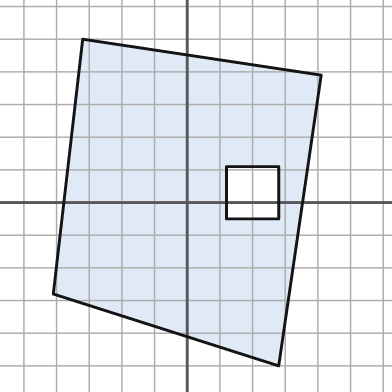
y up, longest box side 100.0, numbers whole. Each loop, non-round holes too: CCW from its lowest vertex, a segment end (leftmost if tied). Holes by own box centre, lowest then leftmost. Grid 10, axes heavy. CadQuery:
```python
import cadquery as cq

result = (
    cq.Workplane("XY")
    .moveTo(28.0, -50.0)
    .lineTo(41.0, 39.0)
    .lineTo(-32.0, 50.0)
    .lineTo(-41.0, -28.0)
    .close()
    .moveTo(12.0, -5.0)
    .lineTo(28.0, -5.0)
    .lineTo(28.0, 11.0)
    .lineTo(12.0, 11.0)
    .close()
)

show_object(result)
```